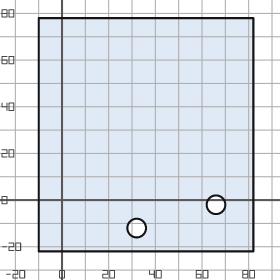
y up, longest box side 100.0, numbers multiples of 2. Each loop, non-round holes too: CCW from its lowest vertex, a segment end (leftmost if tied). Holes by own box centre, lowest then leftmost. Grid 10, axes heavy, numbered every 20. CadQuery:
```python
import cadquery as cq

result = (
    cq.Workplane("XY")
    .moveTo(-10.0, -22.0)
    .lineTo(82.0, -22.0)
    .lineTo(82.0, 78.0)
    .lineTo(-10.0, 78.0)
    .close()
    .moveTo(32.0, -12.0)
    .circle(4.0)
    .moveTo(66.0, -2.0)
    .circle(4.0)
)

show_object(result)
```